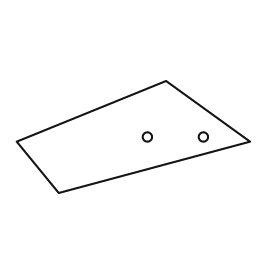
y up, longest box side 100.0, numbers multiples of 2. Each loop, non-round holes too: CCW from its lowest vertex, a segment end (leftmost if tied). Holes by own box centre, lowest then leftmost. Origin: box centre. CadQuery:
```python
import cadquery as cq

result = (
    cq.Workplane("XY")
    .moveTo(-32.0, -24.0)
    .lineTo(50.0, -2.0)
    .lineTo(14.0, 24.0)
    .lineTo(-50.0, -2.0)
    .close()
    .moveTo(6.0, 0.0)
    .circle(2.0)
    .moveTo(30.0, 0.0)
    .circle(2.0)
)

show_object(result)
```